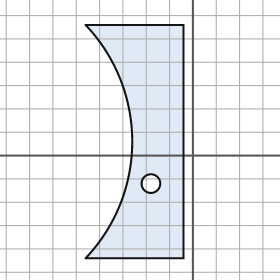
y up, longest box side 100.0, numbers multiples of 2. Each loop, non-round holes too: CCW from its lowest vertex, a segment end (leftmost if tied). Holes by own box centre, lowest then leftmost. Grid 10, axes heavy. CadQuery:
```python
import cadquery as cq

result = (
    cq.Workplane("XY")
    .moveTo(-46.0, -44.0)
    .lineTo(-4.0, -44.0)
    .lineTo(-4.0, 56.0)
    .lineTo(-46.0, 56.0)
    .threePointArc((-26.0, 6.0), (-46.0, -44.0))
    .close()
    .moveTo(-18.0, -12.0)
    .circle(4.0)
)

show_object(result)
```